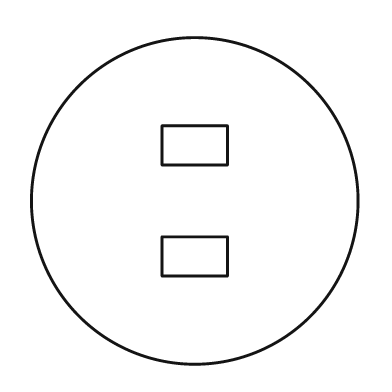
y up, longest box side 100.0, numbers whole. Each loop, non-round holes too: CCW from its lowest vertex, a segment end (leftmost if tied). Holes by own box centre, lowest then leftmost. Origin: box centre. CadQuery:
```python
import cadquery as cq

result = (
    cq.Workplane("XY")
    .moveTo(0.0, 0.0)
    .circle(50.0)
    .moveTo(-10.0, -23.0)
    .lineTo(10.0, -23.0)
    .lineTo(10.0, -11.0)
    .lineTo(-10.0, -11.0)
    .close()
    .moveTo(-10.0, 11.0)
    .lineTo(10.0, 11.0)
    .lineTo(10.0, 23.0)
    .lineTo(-10.0, 23.0)
    .close()
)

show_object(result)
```